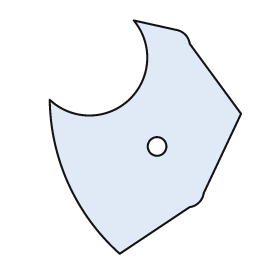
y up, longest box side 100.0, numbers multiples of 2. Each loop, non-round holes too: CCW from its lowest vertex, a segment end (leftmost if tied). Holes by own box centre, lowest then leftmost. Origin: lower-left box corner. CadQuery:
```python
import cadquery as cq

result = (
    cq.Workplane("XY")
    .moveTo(30.0, 0.0)
    .lineTo(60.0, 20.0)
    .threePointArc((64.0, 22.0), (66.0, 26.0))
    .lineTo(82.0, 60.0)
    .lineTo(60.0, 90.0)
    .threePointArc((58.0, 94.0), (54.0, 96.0))
    .lineTo(36.0, 100.0)
    .threePointArc((34.0, 66.0), (0.0, 66.0))
    .threePointArc((8.0, 30.0), (30.0, 0.0))
    .close()
    .moveTo(46.0, 46.0)
    .circle(4.0)
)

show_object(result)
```